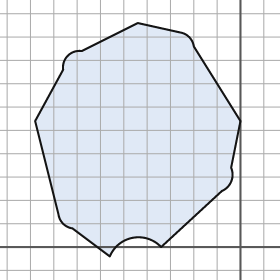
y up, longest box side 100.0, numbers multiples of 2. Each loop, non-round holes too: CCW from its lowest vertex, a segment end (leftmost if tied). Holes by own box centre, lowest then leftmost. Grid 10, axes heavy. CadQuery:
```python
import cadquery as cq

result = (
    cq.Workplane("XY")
    .moveTo(-56.0, -4.0)
    .threePointArc((-46.0, 4.0), (-34.0, 0.0))
    .lineTo(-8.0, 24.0)
    .threePointArc((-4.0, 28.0), (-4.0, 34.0))
    .lineTo(0.0, 54.0)
    .lineTo(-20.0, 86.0)
    .threePointArc((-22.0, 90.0), (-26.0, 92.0))
    .lineTo(-44.0, 96.0)
    .lineTo(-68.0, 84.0)
    .threePointArc((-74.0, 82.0), (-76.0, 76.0))
    .lineTo(-88.0, 54.0)
    .lineTo(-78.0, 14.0)
    .threePointArc((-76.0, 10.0), (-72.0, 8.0))
    .close()
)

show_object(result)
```